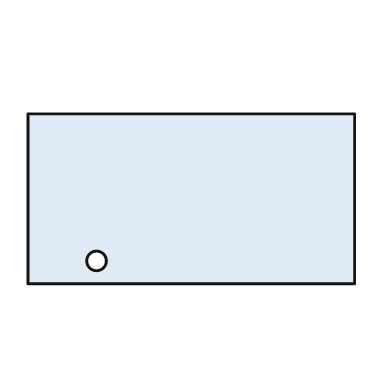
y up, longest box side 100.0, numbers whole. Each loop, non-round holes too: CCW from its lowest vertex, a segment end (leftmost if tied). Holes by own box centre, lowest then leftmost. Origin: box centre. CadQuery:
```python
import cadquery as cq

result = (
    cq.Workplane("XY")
    .moveTo(-50.0, -26.0)
    .lineTo(50.0, -26.0)
    .lineTo(50.0, 26.0)
    .lineTo(-50.0, 26.0)
    .close()
    .moveTo(-29.0, -19.0)
    .circle(3.0)
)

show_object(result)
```